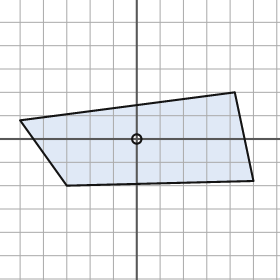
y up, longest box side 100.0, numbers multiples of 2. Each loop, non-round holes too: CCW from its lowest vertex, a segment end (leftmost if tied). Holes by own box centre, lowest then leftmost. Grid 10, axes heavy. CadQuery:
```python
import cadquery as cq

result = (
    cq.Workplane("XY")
    .moveTo(-30.0, -20.0)
    .lineTo(50.0, -18.0)
    .lineTo(42.0, 20.0)
    .lineTo(-50.0, 8.0)
    .close()
    .moveTo(0.0, 0.0)
    .circle(2.0)
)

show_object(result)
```